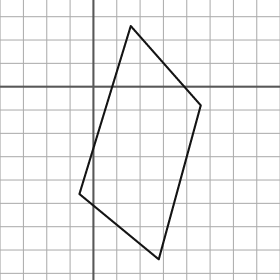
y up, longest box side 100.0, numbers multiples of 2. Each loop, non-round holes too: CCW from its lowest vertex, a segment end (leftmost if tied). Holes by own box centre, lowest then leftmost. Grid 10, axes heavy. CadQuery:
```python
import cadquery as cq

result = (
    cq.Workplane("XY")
    .moveTo(28.0, -74.0)
    .lineTo(46.0, -8.0)
    .lineTo(16.0, 26.0)
    .lineTo(-6.0, -46.0)
    .close()
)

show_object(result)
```